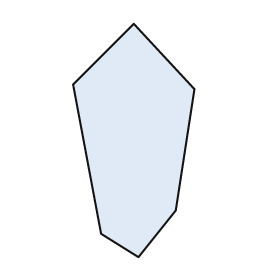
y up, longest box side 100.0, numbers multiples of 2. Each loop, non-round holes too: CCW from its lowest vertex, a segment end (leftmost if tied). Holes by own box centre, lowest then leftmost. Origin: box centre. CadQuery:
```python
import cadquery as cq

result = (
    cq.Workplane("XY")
    .moveTo(2.0, -50.0)
    .lineTo(18.0, -30.0)
    .lineTo(26.0, 22.0)
    .lineTo(0.0, 50.0)
    .lineTo(-26.0, 24.0)
    .lineTo(-14.0, -40.0)
    .close()
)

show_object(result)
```